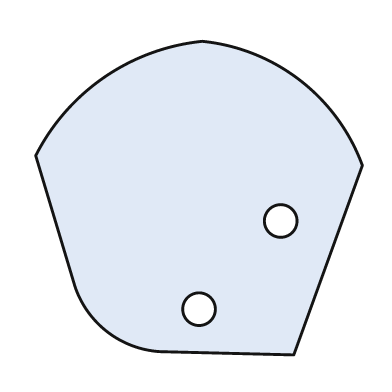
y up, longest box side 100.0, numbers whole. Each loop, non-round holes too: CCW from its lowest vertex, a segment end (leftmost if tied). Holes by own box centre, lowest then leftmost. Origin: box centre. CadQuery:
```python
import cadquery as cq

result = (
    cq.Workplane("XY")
    .moveTo(29.0, -48.0)
    .lineTo(50.0, 10.0)
    .threePointArc((31.0, 36.0), (1.0, 48.0))
    .threePointArc((-29.0, 37.0), (-50.0, 13.0))
    .lineTo(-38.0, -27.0)
    .threePointArc((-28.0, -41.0), (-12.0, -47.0))
    .close()
    .moveTo(0.0, -34.0)
    .circle(5.0)
    .moveTo(25.0, -7.0)
    .circle(5.0)
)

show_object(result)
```